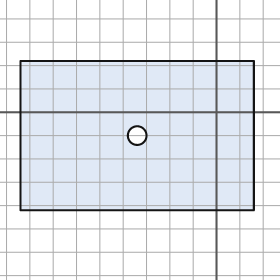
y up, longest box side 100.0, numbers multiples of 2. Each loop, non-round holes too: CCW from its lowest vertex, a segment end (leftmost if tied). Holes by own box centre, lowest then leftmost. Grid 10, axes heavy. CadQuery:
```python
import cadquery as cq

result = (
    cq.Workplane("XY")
    .moveTo(-84.0, -42.0)
    .lineTo(16.0, -42.0)
    .lineTo(16.0, 22.0)
    .lineTo(-84.0, 22.0)
    .close()
    .moveTo(-34.0, -10.0)
    .circle(4.0)
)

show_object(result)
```